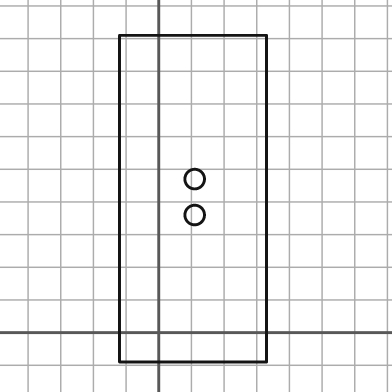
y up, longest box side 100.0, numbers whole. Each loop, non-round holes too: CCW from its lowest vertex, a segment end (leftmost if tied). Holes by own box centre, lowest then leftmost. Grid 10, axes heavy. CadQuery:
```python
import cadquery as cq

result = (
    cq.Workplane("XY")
    .moveTo(-12.0, -9.0)
    .lineTo(33.0, -9.0)
    .lineTo(33.0, 91.0)
    .lineTo(-12.0, 91.0)
    .close()
    .moveTo(11.0, 36.0)
    .circle(3.0)
    .moveTo(11.0, 47.0)
    .circle(3.0)
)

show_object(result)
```